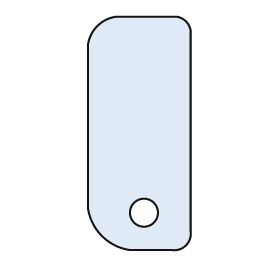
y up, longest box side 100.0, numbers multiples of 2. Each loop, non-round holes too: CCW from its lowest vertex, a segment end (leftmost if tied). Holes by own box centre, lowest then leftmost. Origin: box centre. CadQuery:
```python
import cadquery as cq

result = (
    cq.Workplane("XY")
    .moveTo(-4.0, -50.0)
    .lineTo(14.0, -50.0)
    .threePointArc((20.0, -48.0), (22.0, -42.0))
    .lineTo(22.0, 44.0)
    .threePointArc((20.0, 48.0), (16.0, 50.0))
    .lineTo(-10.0, 50.0)
    .threePointArc((-18.0, 46.0), (-22.0, 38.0))
    .lineTo(-22.0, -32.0)
    .threePointArc((-16.0, -44.0), (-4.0, -50.0))
    .close()
    .moveTo(2.0, -34.0)
    .circle(6.0)
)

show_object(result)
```